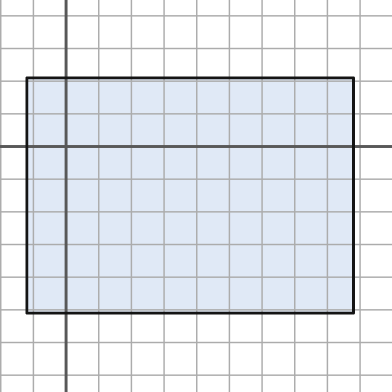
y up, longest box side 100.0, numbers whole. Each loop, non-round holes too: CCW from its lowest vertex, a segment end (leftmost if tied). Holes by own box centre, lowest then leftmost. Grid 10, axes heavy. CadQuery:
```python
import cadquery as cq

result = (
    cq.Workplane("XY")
    .moveTo(-12.0, -51.0)
    .lineTo(88.0, -51.0)
    .lineTo(88.0, 21.0)
    .lineTo(-12.0, 21.0)
    .close()
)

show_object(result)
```